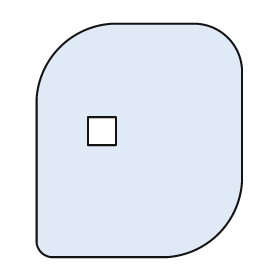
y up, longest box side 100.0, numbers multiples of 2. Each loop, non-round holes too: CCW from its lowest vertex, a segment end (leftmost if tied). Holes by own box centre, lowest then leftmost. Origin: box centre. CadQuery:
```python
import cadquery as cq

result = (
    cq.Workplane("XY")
    .moveTo(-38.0, -50.0)
    .lineTo(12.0, -50.0)
    .threePointArc((34.0, -40.0), (44.0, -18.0))
    .lineTo(44.0, 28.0)
    .threePointArc((38.0, 44.0), (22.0, 50.0))
    .lineTo(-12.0, 50.0)
    .threePointArc((-34.0, 40.0), (-44.0, 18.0))
    .lineTo(-44.0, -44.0)
    .threePointArc((-42.0, -48.0), (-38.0, -50.0))
    .close()
    .moveTo(-22.0, -2.0)
    .lineTo(-10.0, -2.0)
    .lineTo(-10.0, 10.0)
    .lineTo(-22.0, 10.0)
    .close()
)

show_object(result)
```